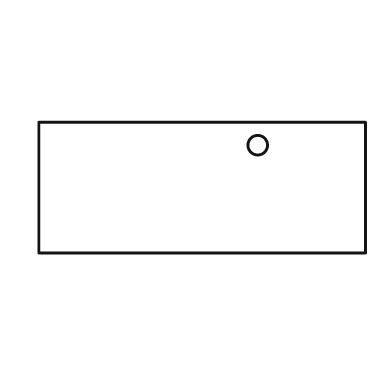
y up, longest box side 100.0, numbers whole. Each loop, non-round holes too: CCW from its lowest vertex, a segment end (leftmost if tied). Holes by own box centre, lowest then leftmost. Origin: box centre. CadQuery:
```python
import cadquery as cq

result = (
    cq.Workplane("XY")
    .moveTo(-50.0, -20.0)
    .lineTo(50.0, -20.0)
    .lineTo(50.0, 20.0)
    .lineTo(-50.0, 20.0)
    .close()
    .moveTo(17.0, 13.0)
    .circle(3.0)
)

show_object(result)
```